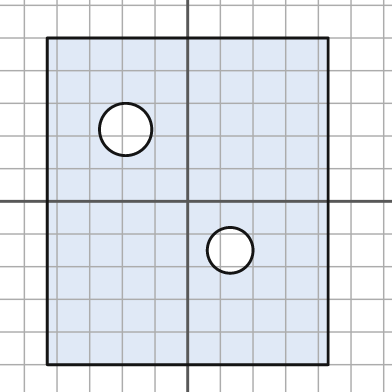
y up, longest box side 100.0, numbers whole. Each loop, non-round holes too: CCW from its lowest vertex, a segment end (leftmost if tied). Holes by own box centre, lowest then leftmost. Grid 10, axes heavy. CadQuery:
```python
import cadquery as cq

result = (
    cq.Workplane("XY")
    .moveTo(-43.0, -50.0)
    .lineTo(43.0, -50.0)
    .lineTo(43.0, 50.0)
    .lineTo(-43.0, 50.0)
    .close()
    .moveTo(13.0, -15.0)
    .circle(7.0)
    .moveTo(-19.0, 22.0)
    .circle(8.0)
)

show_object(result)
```